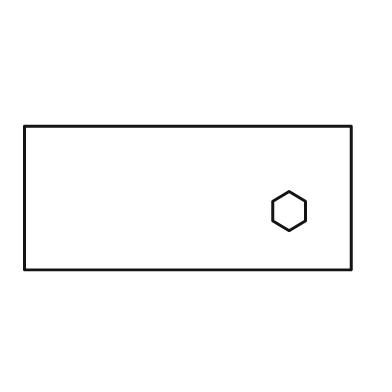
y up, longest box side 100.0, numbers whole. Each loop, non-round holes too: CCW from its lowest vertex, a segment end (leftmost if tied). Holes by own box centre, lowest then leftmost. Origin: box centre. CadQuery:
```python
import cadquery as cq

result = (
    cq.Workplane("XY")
    .moveTo(-50.0, -22.0)
    .lineTo(50.0, -22.0)
    .lineTo(50.0, 22.0)
    .lineTo(-50.0, 22.0)
    .close()
    .moveTo(31.0, -10.0)
    .lineTo(36.0, -7.0)
    .lineTo(36.0, -1.0)
    .lineTo(31.0, 2.0)
    .lineTo(26.0, -1.0)
    .lineTo(26.0, -7.0)
    .close()
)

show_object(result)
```